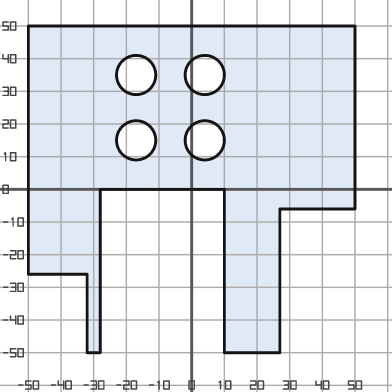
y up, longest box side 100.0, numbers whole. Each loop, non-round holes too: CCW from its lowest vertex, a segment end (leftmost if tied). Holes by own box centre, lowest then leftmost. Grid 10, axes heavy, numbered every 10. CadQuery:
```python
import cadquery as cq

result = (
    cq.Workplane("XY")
    .moveTo(-32.0, -50.0)
    .lineTo(-28.0, -50.0)
    .lineTo(-28.0, 0.0)
    .lineTo(10.0, 0.0)
    .lineTo(10.0, -50.0)
    .lineTo(27.0, -50.0)
    .lineTo(27.0, -6.0)
    .lineTo(50.0, -6.0)
    .lineTo(50.0, 50.0)
    .lineTo(-50.0, 50.0)
    .lineTo(-50.0, -26.0)
    .lineTo(-32.0, -26.0)
    .close()
    .moveTo(-17.0, 15.0)
    .circle(6.0)
    .moveTo(4.0, 15.0)
    .circle(6.0)
    .moveTo(-17.0, 35.0)
    .circle(6.0)
    .moveTo(4.0, 35.0)
    .circle(6.0)
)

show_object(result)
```